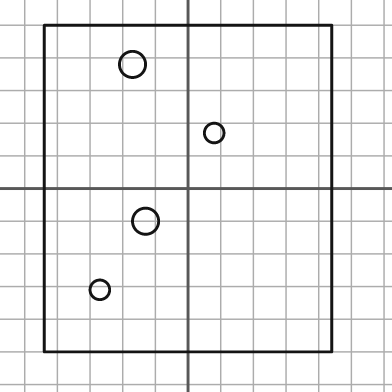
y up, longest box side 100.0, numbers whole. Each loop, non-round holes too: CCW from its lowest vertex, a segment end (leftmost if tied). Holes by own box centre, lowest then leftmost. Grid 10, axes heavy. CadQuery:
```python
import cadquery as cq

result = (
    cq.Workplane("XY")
    .moveTo(-44.0, -50.0)
    .lineTo(44.0, -50.0)
    .lineTo(44.0, 50.0)
    .lineTo(-44.0, 50.0)
    .close()
    .moveTo(-27.0, -31.0)
    .circle(3.0)
    .moveTo(-13.0, -10.0)
    .circle(4.0)
    .moveTo(8.0, 17.0)
    .circle(3.0)
    .moveTo(-17.0, 38.0)
    .circle(4.0)
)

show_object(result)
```